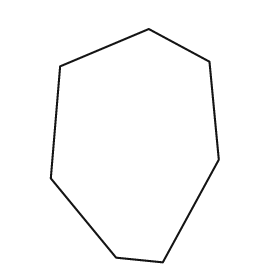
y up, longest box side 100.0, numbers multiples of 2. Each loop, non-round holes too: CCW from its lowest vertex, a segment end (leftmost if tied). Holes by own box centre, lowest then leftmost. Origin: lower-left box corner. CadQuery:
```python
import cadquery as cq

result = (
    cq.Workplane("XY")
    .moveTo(48.0, 0.0)
    .lineTo(72.0, 44.0)
    .lineTo(68.0, 86.0)
    .lineTo(42.0, 100.0)
    .lineTo(4.0, 84.0)
    .lineTo(0.0, 36.0)
    .lineTo(28.0, 2.0)
    .close()
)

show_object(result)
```